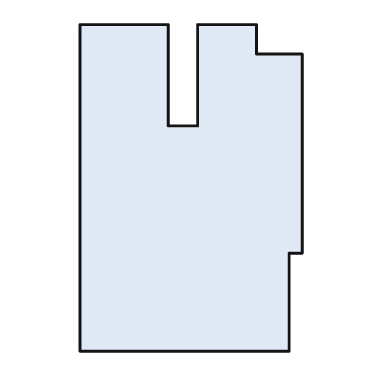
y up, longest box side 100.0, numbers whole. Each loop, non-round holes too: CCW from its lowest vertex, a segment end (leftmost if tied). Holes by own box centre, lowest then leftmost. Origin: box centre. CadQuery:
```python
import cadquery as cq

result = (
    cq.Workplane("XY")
    .moveTo(-34.0, -50.0)
    .lineTo(30.0, -50.0)
    .lineTo(30.0, -20.0)
    .lineTo(34.0, -20.0)
    .lineTo(34.0, 41.0)
    .lineTo(20.0, 41.0)
    .lineTo(20.0, 50.0)
    .lineTo(2.0, 50.0)
    .lineTo(2.0, 19.0)
    .lineTo(-7.0, 19.0)
    .lineTo(-7.0, 50.0)
    .lineTo(-34.0, 50.0)
    .close()
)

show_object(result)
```